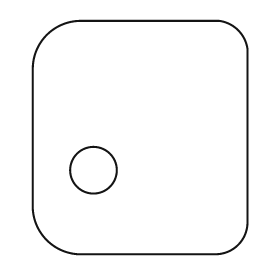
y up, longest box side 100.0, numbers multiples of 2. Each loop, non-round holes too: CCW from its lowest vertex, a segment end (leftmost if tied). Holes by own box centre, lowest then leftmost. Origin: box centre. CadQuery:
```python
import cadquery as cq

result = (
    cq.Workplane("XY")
    .moveTo(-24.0, -50.0)
    .lineTo(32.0, -50.0)
    .threePointArc((42.0, -46.0), (46.0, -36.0))
    .lineTo(46.0, 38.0)
    .threePointArc((42.0, 46.0), (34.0, 50.0))
    .lineTo(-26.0, 50.0)
    .threePointArc((-40.0, 44.0), (-46.0, 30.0))
    .lineTo(-46.0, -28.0)
    .threePointArc((-40.0, -44.0), (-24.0, -50.0))
    .close()
    .moveTo(-20.0, -14.0)
    .circle(10.0)
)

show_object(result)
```